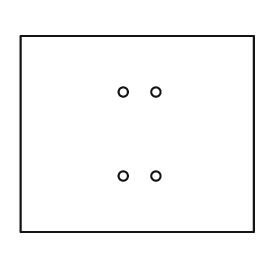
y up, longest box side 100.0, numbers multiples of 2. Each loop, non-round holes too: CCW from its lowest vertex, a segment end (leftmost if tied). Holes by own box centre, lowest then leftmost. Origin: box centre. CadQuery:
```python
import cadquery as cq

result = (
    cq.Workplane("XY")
    .moveTo(-50.0, -42.0)
    .lineTo(50.0, -42.0)
    .lineTo(50.0, 42.0)
    .lineTo(-50.0, 42.0)
    .close()
    .moveTo(-6.0, -18.0)
    .circle(2.0)
    .moveTo(8.0, -18.0)
    .circle(2.0)
    .moveTo(-6.0, 18.0)
    .circle(2.0)
    .moveTo(8.0, 18.0)
    .circle(2.0)
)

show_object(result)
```